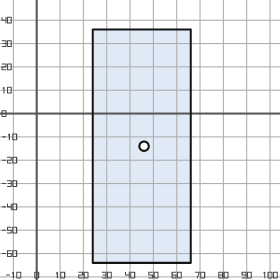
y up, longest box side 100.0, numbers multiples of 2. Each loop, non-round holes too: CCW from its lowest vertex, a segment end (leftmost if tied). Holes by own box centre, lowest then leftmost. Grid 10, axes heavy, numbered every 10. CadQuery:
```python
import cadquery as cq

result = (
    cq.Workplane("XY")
    .moveTo(24.0, -64.0)
    .lineTo(66.0, -64.0)
    .lineTo(66.0, 36.0)
    .lineTo(24.0, 36.0)
    .close()
    .moveTo(46.0, -14.0)
    .circle(2.0)
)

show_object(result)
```